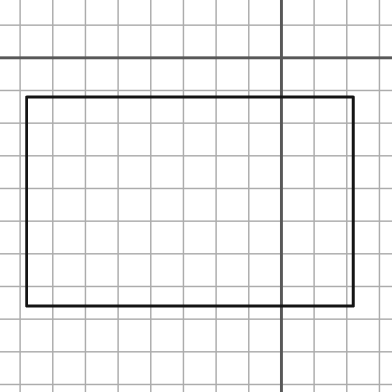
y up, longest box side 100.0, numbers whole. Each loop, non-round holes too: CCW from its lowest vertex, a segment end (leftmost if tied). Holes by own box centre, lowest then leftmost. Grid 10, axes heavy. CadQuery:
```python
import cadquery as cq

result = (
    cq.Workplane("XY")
    .moveTo(-78.0, -76.0)
    .lineTo(22.0, -76.0)
    .lineTo(22.0, -12.0)
    .lineTo(-78.0, -12.0)
    .close()
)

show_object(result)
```